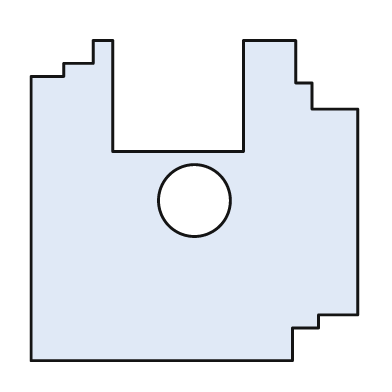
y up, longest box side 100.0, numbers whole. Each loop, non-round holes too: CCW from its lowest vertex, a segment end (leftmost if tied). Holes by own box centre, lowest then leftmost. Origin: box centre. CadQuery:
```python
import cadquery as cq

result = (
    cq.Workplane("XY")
    .moveTo(-50.0, -49.0)
    .lineTo(30.0, -49.0)
    .lineTo(30.0, -39.0)
    .lineTo(38.0, -39.0)
    .lineTo(38.0, -35.0)
    .lineTo(50.0, -35.0)
    .lineTo(50.0, 28.0)
    .lineTo(36.0, 28.0)
    .lineTo(36.0, 36.0)
    .lineTo(31.0, 36.0)
    .lineTo(31.0, 49.0)
    .lineTo(15.0, 49.0)
    .lineTo(15.0, 15.0)
    .lineTo(-25.0, 15.0)
    .lineTo(-25.0, 49.0)
    .lineTo(-31.0, 49.0)
    .lineTo(-31.0, 42.0)
    .lineTo(-40.0, 42.0)
    .lineTo(-40.0, 38.0)
    .lineTo(-50.0, 38.0)
    .close()
    .moveTo(0.0, 0.0)
    .circle(11.0)
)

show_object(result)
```